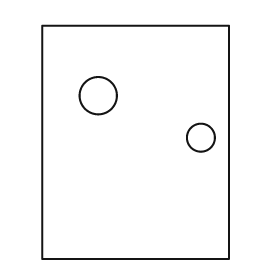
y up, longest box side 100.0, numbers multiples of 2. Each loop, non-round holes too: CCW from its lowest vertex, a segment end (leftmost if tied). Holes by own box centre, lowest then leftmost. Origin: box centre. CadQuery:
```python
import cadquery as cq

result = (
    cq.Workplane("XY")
    .moveTo(-40.0, -50.0)
    .lineTo(40.0, -50.0)
    .lineTo(40.0, 50.0)
    .lineTo(-40.0, 50.0)
    .close()
    .moveTo(28.0, 2.0)
    .circle(6.0)
    .moveTo(-16.0, 20.0)
    .circle(8.0)
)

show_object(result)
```